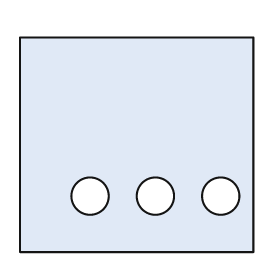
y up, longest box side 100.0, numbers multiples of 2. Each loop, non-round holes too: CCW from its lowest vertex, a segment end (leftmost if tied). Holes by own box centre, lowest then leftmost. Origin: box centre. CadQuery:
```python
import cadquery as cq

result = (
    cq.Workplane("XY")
    .moveTo(-50.0, -46.0)
    .lineTo(50.0, -46.0)
    .lineTo(50.0, 46.0)
    .lineTo(-50.0, 46.0)
    .close()
    .moveTo(-20.0, -22.0)
    .circle(8.0)
    .moveTo(8.0, -22.0)
    .circle(8.0)
    .moveTo(36.0, -22.0)
    .circle(8.0)
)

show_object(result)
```